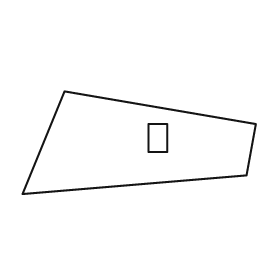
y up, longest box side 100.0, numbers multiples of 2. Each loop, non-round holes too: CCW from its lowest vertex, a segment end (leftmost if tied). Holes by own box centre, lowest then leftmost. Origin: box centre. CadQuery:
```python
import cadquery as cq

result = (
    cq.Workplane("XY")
    .moveTo(-50.0, -22.0)
    .lineTo(46.0, -14.0)
    .lineTo(50.0, 8.0)
    .lineTo(-32.0, 22.0)
    .close()
    .moveTo(4.0, -4.0)
    .lineTo(12.0, -4.0)
    .lineTo(12.0, 8.0)
    .lineTo(4.0, 8.0)
    .close()
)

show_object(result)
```